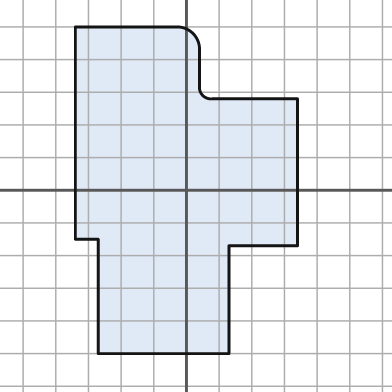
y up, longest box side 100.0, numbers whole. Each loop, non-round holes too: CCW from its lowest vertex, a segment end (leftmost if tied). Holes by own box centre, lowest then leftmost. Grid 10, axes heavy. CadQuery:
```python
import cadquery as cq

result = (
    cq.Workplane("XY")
    .moveTo(-27.0, -50.0)
    .lineTo(13.0, -50.0)
    .lineTo(13.0, -17.0)
    .lineTo(34.0, -17.0)
    .lineTo(34.0, 28.0)
    .lineTo(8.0, 28.0)
    .threePointArc((5.0, 29.0), (4.0, 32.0))
    .lineTo(4.0, 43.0)
    .threePointArc((2.0, 48.0), (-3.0, 50.0))
    .lineTo(-34.0, 50.0)
    .lineTo(-34.0, -15.0)
    .lineTo(-27.0, -15.0)
    .close()
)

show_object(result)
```